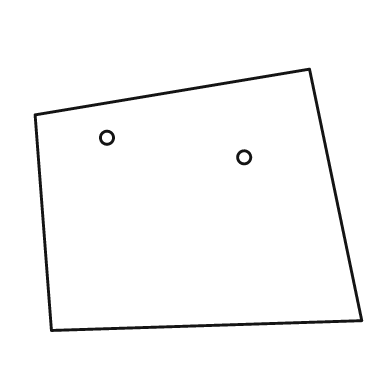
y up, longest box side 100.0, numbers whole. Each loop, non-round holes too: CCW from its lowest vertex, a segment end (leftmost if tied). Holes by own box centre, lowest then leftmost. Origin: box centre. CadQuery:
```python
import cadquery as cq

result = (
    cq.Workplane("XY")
    .moveTo(-45.0, -40.0)
    .lineTo(50.0, -37.0)
    .lineTo(34.0, 40.0)
    .lineTo(-50.0, 26.0)
    .close()
    .moveTo(14.0, 13.0)
    .circle(2.0)
    .moveTo(-28.0, 19.0)
    .circle(2.0)
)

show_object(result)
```